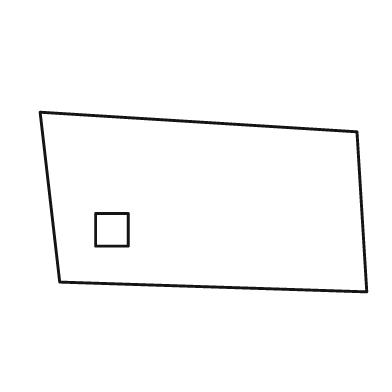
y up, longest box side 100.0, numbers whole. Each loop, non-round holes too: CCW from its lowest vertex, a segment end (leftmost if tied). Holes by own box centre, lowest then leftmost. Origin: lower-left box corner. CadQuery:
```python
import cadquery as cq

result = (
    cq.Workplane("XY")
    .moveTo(100.0, 0.0)
    .lineTo(97.0, 49.0)
    .lineTo(0.0, 55.0)
    .lineTo(6.0, 3.0)
    .close()
    .moveTo(17.0, 14.0)
    .lineTo(27.0, 14.0)
    .lineTo(27.0, 24.0)
    .lineTo(17.0, 24.0)
    .close()
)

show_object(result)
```